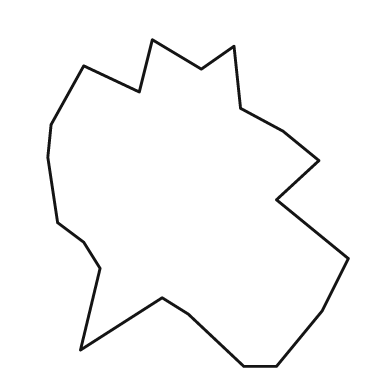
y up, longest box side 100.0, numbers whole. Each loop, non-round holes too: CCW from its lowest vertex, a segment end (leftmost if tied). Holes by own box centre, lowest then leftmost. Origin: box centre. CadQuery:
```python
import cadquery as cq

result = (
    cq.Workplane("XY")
    .moveTo(14.0, -50.0)
    .lineTo(24.0, -50.0)
    .lineTo(38.0, -33.0)
    .lineTo(46.0, -17.0)
    .lineTo(24.0, 1.0)
    .lineTo(37.0, 13.0)
    .lineTo(26.0, 22.0)
    .lineTo(13.0, 29.0)
    .lineTo(11.0, 48.0)
    .lineTo(1.0, 41.0)
    .lineTo(-14.0, 50.0)
    .lineTo(-18.0, 34.0)
    .lineTo(-35.0, 42.0)
    .lineTo(-45.0, 24.0)
    .lineTo(-46.0, 14.0)
    .lineTo(-43.0, -6.0)
    .lineTo(-35.0, -12.0)
    .lineTo(-30.0, -20.0)
    .lineTo(-36.0, -45.0)
    .lineTo(-11.0, -29.0)
    .lineTo(-3.0, -34.0)
    .close()
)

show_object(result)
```